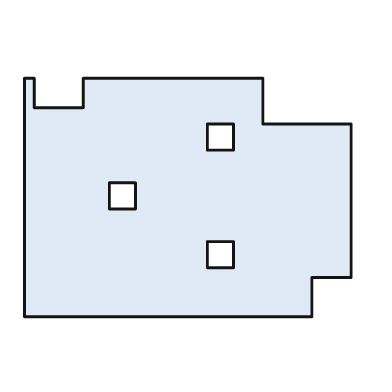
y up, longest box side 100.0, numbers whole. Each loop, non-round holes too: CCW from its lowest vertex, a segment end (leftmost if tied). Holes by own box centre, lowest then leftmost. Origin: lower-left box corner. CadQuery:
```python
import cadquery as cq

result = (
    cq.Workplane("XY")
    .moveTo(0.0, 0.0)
    .lineTo(88.0, 0.0)
    .lineTo(88.0, 12.0)
    .lineTo(100.0, 12.0)
    .lineTo(100.0, 59.0)
    .lineTo(73.0, 59.0)
    .lineTo(73.0, 73.0)
    .lineTo(18.0, 73.0)
    .lineTo(18.0, 64.0)
    .lineTo(3.0, 64.0)
    .lineTo(3.0, 73.0)
    .lineTo(0.0, 73.0)
    .close()
    .moveTo(56.0, 15.0)
    .lineTo(64.0, 15.0)
    .lineTo(64.0, 23.0)
    .lineTo(56.0, 23.0)
    .close()
    .moveTo(26.0, 33.0)
    .lineTo(34.0, 33.0)
    .lineTo(34.0, 41.0)
    .lineTo(26.0, 41.0)
    .close()
    .moveTo(56.0, 51.0)
    .lineTo(64.0, 51.0)
    .lineTo(64.0, 59.0)
    .lineTo(56.0, 59.0)
    .close()
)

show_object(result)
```